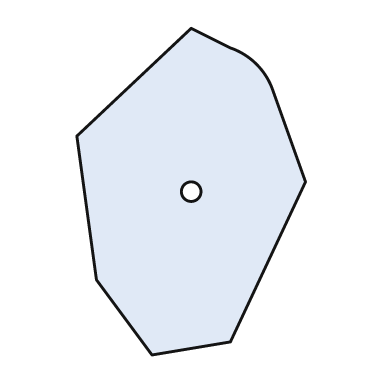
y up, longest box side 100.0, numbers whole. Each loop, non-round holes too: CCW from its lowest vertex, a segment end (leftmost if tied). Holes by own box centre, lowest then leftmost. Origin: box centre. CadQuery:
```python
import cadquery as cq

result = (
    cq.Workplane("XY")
    .moveTo(-12.0, -50.0)
    .lineTo(12.0, -46.0)
    .lineTo(35.0, 3.0)
    .lineTo(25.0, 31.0)
    .threePointArc((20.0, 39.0), (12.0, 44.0))
    .lineTo(0.0, 50.0)
    .lineTo(-35.0, 17.0)
    .lineTo(-29.0, -27.0)
    .close()
    .moveTo(0.0, 0.0)
    .circle(3.0)
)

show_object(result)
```